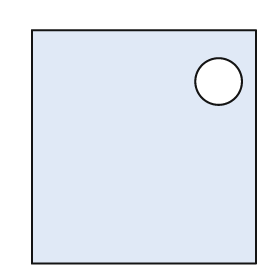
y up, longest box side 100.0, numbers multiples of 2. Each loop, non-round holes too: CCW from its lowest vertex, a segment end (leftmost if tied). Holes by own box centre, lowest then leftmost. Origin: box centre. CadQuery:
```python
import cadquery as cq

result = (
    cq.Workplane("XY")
    .moveTo(-48.0, -50.0)
    .lineTo(48.0, -50.0)
    .lineTo(48.0, 50.0)
    .lineTo(-48.0, 50.0)
    .close()
    .moveTo(32.0, 28.0)
    .circle(10.0)
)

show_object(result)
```